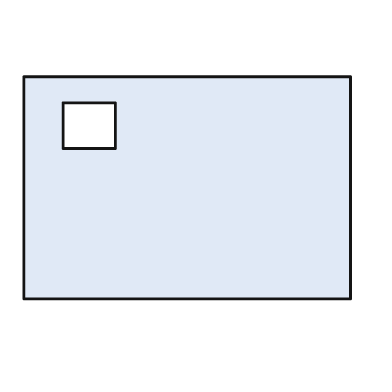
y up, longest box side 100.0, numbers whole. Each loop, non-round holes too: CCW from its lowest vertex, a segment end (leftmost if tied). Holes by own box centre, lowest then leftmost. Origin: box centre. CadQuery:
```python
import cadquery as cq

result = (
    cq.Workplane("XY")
    .moveTo(-50.0, -34.0)
    .lineTo(50.0, -34.0)
    .lineTo(50.0, 34.0)
    .lineTo(-50.0, 34.0)
    .close()
    .moveTo(-38.0, 12.0)
    .lineTo(-22.0, 12.0)
    .lineTo(-22.0, 26.0)
    .lineTo(-38.0, 26.0)
    .close()
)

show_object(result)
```